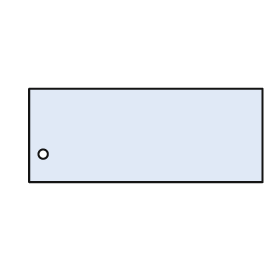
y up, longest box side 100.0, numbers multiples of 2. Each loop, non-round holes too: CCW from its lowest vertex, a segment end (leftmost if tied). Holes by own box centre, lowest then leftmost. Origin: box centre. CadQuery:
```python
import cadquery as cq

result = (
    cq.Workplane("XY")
    .moveTo(-50.0, -20.0)
    .lineTo(50.0, -20.0)
    .lineTo(50.0, 20.0)
    .lineTo(-50.0, 20.0)
    .close()
    .moveTo(-44.0, -8.0)
    .circle(2.0)
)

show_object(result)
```